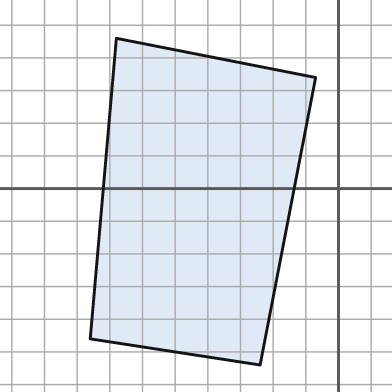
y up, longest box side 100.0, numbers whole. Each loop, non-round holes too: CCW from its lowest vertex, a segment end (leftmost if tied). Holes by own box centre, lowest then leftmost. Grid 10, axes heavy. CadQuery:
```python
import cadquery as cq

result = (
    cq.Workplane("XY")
    .moveTo(-24.0, -54.0)
    .lineTo(-7.0, 34.0)
    .lineTo(-68.0, 46.0)
    .lineTo(-76.0, -46.0)
    .close()
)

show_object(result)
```